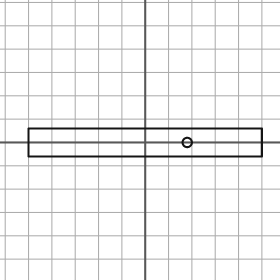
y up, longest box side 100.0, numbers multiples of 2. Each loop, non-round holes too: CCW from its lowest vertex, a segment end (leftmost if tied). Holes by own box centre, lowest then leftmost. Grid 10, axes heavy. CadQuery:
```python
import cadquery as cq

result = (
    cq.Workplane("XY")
    .moveTo(-50.0, -6.0)
    .lineTo(50.0, -6.0)
    .lineTo(50.0, 6.0)
    .lineTo(-50.0, 6.0)
    .close()
    .moveTo(18.0, 0.0)
    .circle(2.0)
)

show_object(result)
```